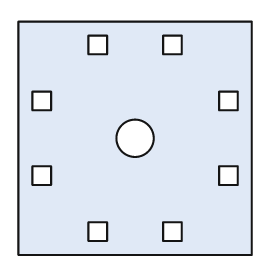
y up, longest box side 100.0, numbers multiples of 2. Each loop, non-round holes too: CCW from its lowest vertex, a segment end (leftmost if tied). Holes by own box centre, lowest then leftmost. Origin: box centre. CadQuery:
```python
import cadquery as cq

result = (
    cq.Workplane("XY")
    .moveTo(-50.0, -50.0)
    .lineTo(50.0, -50.0)
    .lineTo(50.0, 50.0)
    .lineTo(-50.0, 50.0)
    .close()
    .moveTo(-20.0, -44.0)
    .lineTo(-12.0, -44.0)
    .lineTo(-12.0, -36.0)
    .lineTo(-20.0, -36.0)
    .close()
    .moveTo(12.0, -44.0)
    .lineTo(20.0, -44.0)
    .lineTo(20.0, -36.0)
    .lineTo(12.0, -36.0)
    .close()
    .moveTo(-44.0, -20.0)
    .lineTo(-36.0, -20.0)
    .lineTo(-36.0, -12.0)
    .lineTo(-44.0, -12.0)
    .close()
    .moveTo(36.0, -20.0)
    .lineTo(44.0, -20.0)
    .lineTo(44.0, -12.0)
    .lineTo(36.0, -12.0)
    .close()
    .moveTo(0.0, 0.0)
    .circle(8.0)
    .moveTo(-44.0, 12.0)
    .lineTo(-36.0, 12.0)
    .lineTo(-36.0, 20.0)
    .lineTo(-44.0, 20.0)
    .close()
    .moveTo(36.0, 12.0)
    .lineTo(44.0, 12.0)
    .lineTo(44.0, 20.0)
    .lineTo(36.0, 20.0)
    .close()
    .moveTo(-20.0, 36.0)
    .lineTo(-12.0, 36.0)
    .lineTo(-12.0, 44.0)
    .lineTo(-20.0, 44.0)
    .close()
    .moveTo(12.0, 36.0)
    .lineTo(20.0, 36.0)
    .lineTo(20.0, 44.0)
    .lineTo(12.0, 44.0)
    .close()
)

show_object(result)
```